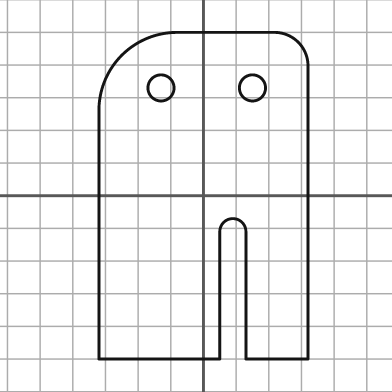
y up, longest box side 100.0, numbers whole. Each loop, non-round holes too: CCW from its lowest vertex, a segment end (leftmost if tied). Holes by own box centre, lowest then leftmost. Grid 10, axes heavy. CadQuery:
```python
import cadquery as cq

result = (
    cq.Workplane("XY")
    .moveTo(-32.0, -50.0)
    .lineTo(5.0, -50.0)
    .lineTo(5.0, -11.0)
    .threePointArc((9.0, -7.0), (13.0, -11.0))
    .lineTo(13.0, -50.0)
    .lineTo(32.0, -50.0)
    .lineTo(32.0, 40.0)
    .threePointArc((29.0, 47.0), (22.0, 50.0))
    .lineTo(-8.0, 50.0)
    .threePointArc((-25.0, 43.0), (-32.0, 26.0))
    .close()
    .moveTo(-13.0, 33.0)
    .circle(4.0)
    .moveTo(15.0, 33.0)
    .circle(4.0)
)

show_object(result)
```